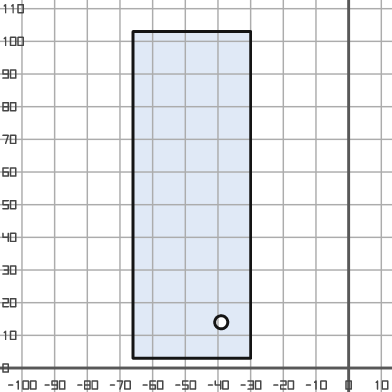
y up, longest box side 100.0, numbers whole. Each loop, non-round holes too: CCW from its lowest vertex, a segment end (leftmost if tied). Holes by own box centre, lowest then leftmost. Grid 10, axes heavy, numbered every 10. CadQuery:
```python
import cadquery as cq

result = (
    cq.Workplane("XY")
    .moveTo(-66.0, 3.0)
    .lineTo(-30.0, 3.0)
    .lineTo(-30.0, 103.0)
    .lineTo(-66.0, 103.0)
    .close()
    .moveTo(-39.0, 14.0)
    .circle(2.0)
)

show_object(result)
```